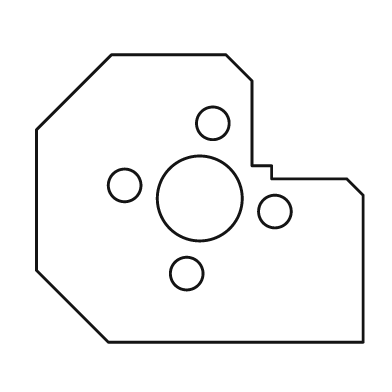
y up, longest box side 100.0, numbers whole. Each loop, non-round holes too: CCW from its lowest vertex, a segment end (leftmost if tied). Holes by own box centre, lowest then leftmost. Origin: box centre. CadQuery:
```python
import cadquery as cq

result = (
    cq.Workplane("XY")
    .moveTo(-28.0, -44.0)
    .lineTo(50.0, -44.0)
    .lineTo(50.0, 1.0)
    .lineTo(45.0, 6.0)
    .lineTo(22.0, 6.0)
    .lineTo(22.0, 10.0)
    .lineTo(16.0, 10.0)
    .lineTo(16.0, 36.0)
    .lineTo(8.0, 44.0)
    .lineTo(-27.0, 44.0)
    .lineTo(-50.0, 21.0)
    .lineTo(-50.0, -22.0)
    .close()
    .moveTo(-4.0, -23.0)
    .circle(5.0)
    .moveTo(23.0, -4.0)
    .circle(5.0)
    .moveTo(0.0, 0.0)
    .circle(13.0)
    .moveTo(-23.0, 4.0)
    .circle(5.0)
    .moveTo(4.0, 23.0)
    .circle(5.0)
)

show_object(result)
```